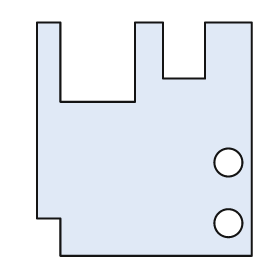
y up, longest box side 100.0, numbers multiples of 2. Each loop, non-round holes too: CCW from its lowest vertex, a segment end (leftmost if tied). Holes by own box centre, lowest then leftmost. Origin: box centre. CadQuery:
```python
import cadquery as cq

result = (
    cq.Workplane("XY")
    .moveTo(-36.0, -50.0)
    .lineTo(46.0, -50.0)
    .lineTo(46.0, 50.0)
    .lineTo(26.0, 50.0)
    .lineTo(26.0, 26.0)
    .lineTo(8.0, 26.0)
    .lineTo(8.0, 50.0)
    .lineTo(-4.0, 50.0)
    .lineTo(-4.0, 16.0)
    .lineTo(-36.0, 16.0)
    .lineTo(-36.0, 50.0)
    .lineTo(-46.0, 50.0)
    .lineTo(-46.0, -34.0)
    .lineTo(-36.0, -34.0)
    .close()
    .moveTo(36.0, -36.0)
    .circle(6.0)
    .moveTo(36.0, -10.0)
    .circle(6.0)
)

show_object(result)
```